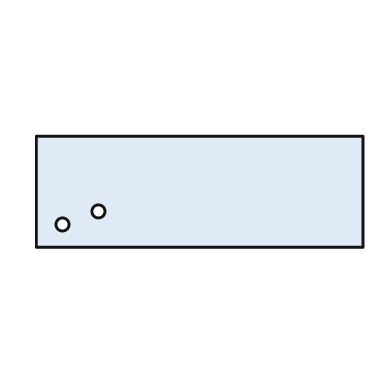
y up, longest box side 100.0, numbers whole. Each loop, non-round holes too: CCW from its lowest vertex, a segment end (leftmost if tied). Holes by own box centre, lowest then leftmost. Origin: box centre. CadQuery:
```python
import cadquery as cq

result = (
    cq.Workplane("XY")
    .moveTo(-50.0, -17.0)
    .lineTo(50.0, -17.0)
    .lineTo(50.0, 17.0)
    .lineTo(-50.0, 17.0)
    .close()
    .moveTo(-42.0, -10.0)
    .circle(2.0)
    .moveTo(-31.0, -6.0)
    .circle(2.0)
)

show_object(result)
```